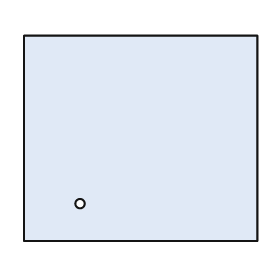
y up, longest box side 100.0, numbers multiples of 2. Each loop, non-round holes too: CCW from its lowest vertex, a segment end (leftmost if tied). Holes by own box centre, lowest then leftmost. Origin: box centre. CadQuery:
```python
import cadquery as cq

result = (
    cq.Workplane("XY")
    .moveTo(-50.0, -44.0)
    .lineTo(50.0, -44.0)
    .lineTo(50.0, 44.0)
    .lineTo(-50.0, 44.0)
    .close()
    .moveTo(-26.0, -28.0)
    .circle(2.0)
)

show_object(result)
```